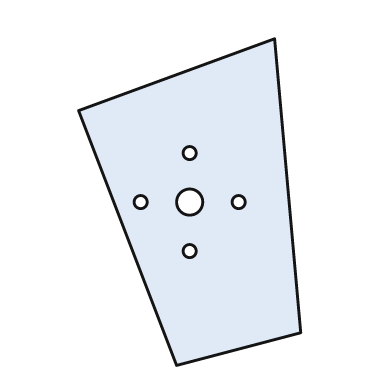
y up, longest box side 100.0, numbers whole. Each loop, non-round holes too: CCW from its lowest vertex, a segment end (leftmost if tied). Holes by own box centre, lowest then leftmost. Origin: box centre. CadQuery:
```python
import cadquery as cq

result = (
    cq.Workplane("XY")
    .moveTo(-4.0, -50.0)
    .lineTo(34.0, -40.0)
    .lineTo(26.0, 50.0)
    .lineTo(-34.0, 28.0)
    .close()
    .moveTo(0.0, -15.0)
    .circle(2.0)
    .moveTo(-15.0, 0.0)
    .circle(2.0)
    .moveTo(0.0, 0.0)
    .circle(4.0)
    .moveTo(15.0, 0.0)
    .circle(2.0)
    .moveTo(0.0, 15.0)
    .circle(2.0)
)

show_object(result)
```